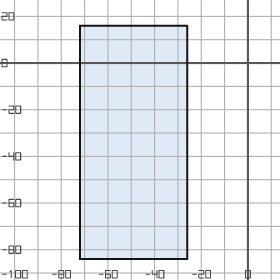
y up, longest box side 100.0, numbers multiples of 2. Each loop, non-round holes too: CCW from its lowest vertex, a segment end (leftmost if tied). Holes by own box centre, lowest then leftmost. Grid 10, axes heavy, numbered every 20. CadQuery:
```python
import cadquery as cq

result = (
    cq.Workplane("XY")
    .moveTo(-72.0, -84.0)
    .lineTo(-26.0, -84.0)
    .lineTo(-26.0, 16.0)
    .lineTo(-72.0, 16.0)
    .close()
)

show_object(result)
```